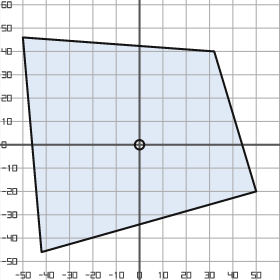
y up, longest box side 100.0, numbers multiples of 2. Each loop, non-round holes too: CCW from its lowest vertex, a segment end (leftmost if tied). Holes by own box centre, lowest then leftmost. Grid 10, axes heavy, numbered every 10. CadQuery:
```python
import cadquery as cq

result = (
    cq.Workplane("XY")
    .moveTo(-42.0, -46.0)
    .lineTo(50.0, -20.0)
    .lineTo(32.0, 40.0)
    .lineTo(-50.0, 46.0)
    .close()
    .moveTo(0.0, 0.0)
    .circle(2.0)
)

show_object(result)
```